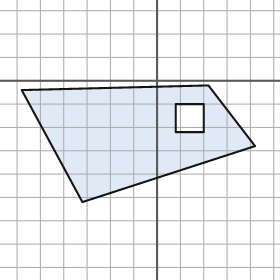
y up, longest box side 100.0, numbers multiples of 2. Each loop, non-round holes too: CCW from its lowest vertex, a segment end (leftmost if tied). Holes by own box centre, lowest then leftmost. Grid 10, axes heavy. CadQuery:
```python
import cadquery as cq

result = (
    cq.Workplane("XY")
    .moveTo(-32.0, -52.0)
    .lineTo(42.0, -28.0)
    .lineTo(22.0, -2.0)
    .lineTo(-58.0, -4.0)
    .close()
    .moveTo(8.0, -22.0)
    .lineTo(20.0, -22.0)
    .lineTo(20.0, -10.0)
    .lineTo(8.0, -10.0)
    .close()
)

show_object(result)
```